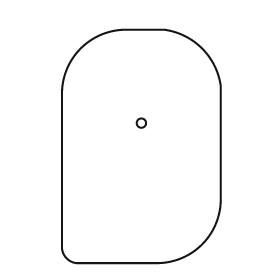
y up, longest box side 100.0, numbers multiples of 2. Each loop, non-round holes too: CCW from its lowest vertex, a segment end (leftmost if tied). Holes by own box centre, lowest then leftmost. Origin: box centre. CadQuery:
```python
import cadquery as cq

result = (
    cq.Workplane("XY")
    .moveTo(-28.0, -50.0)
    .lineTo(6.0, -50.0)
    .threePointArc((26.0, -42.0), (34.0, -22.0))
    .lineTo(34.0, 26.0)
    .threePointArc((26.0, 42.0), (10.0, 50.0))
    .lineTo(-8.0, 50.0)
    .threePointArc((-26.0, 42.0), (-34.0, 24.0))
    .lineTo(-34.0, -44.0)
    .threePointArc((-32.0, -48.0), (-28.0, -50.0))
    .close()
    .moveTo(0.0, 10.0)
    .circle(2.0)
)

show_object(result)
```